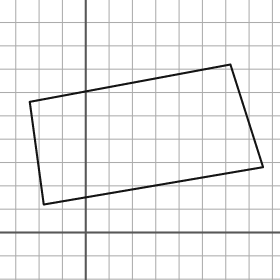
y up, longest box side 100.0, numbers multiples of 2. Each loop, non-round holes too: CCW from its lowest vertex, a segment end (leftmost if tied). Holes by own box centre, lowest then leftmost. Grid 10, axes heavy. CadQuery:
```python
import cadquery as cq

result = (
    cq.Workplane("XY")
    .moveTo(-18.0, 12.0)
    .lineTo(76.0, 28.0)
    .lineTo(62.0, 72.0)
    .lineTo(-24.0, 56.0)
    .close()
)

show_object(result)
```